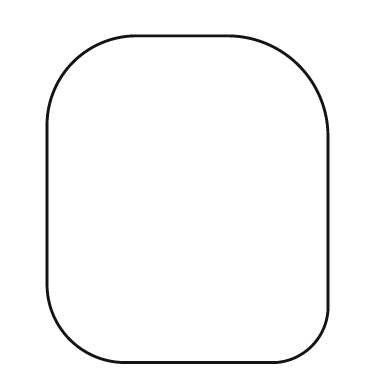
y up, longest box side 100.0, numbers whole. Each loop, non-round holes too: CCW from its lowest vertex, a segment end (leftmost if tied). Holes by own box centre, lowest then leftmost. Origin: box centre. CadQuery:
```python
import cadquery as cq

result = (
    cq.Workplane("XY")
    .moveTo(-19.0, -50.0)
    .lineTo(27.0, -50.0)
    .threePointArc((38.0, -45.0), (43.0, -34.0))
    .lineTo(43.0, 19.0)
    .threePointArc((34.0, 41.0), (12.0, 50.0))
    .lineTo(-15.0, 50.0)
    .threePointArc((-35.0, 42.0), (-43.0, 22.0))
    .lineTo(-43.0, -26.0)
    .threePointArc((-36.0, -43.0), (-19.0, -50.0))
    .close()
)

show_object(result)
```